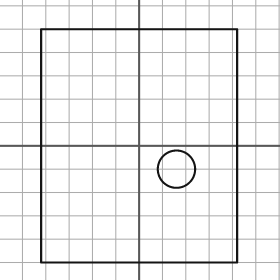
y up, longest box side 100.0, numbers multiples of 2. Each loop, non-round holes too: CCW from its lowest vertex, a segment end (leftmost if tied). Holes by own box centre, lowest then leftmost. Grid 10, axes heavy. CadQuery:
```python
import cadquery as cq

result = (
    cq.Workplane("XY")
    .moveTo(-42.0, -50.0)
    .lineTo(42.0, -50.0)
    .lineTo(42.0, 50.0)
    .lineTo(-42.0, 50.0)
    .close()
    .moveTo(16.0, -10.0)
    .circle(8.0)
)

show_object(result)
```